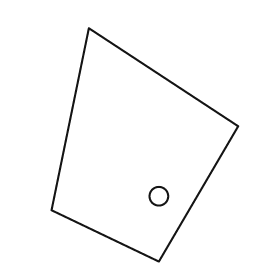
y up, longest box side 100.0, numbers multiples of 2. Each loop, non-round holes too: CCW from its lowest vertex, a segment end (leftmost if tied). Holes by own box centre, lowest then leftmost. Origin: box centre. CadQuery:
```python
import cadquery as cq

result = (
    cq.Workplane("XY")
    .moveTo(6.0, -50.0)
    .lineTo(40.0, 8.0)
    .lineTo(-24.0, 50.0)
    .lineTo(-40.0, -28.0)
    .close()
    .moveTo(6.0, -22.0)
    .circle(4.0)
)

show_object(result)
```